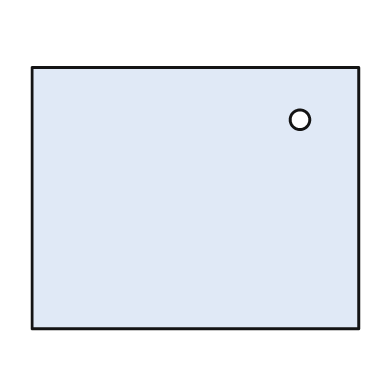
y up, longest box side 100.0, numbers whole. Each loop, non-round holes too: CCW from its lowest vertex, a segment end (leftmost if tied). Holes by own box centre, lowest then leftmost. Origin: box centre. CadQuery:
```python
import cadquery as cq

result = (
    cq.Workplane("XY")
    .moveTo(-50.0, -40.0)
    .lineTo(50.0, -40.0)
    .lineTo(50.0, 40.0)
    .lineTo(-50.0, 40.0)
    .close()
    .moveTo(32.0, 24.0)
    .circle(3.0)
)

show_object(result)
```